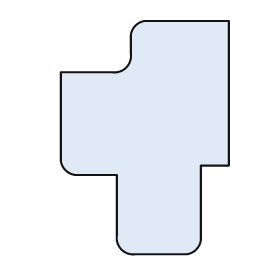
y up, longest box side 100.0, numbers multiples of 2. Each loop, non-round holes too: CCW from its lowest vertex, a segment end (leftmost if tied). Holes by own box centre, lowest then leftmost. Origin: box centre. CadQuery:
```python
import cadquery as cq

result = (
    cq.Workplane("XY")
    .moveTo(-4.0, -50.0)
    .lineTo(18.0, -50.0)
    .threePointArc((22.0, -48.0), (24.0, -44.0))
    .lineTo(24.0, -12.0)
    .lineTo(36.0, -12.0)
    .lineTo(36.0, 50.0)
    .lineTo(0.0, 50.0)
    .threePointArc((-4.0, 48.0), (-6.0, 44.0))
    .lineTo(-6.0, 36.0)
    .threePointArc((-8.0, 30.0), (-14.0, 28.0))
    .lineTo(-36.0, 28.0)
    .lineTo(-36.0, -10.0)
    .threePointArc((-34.0, -14.0), (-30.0, -16.0))
    .lineTo(-12.0, -16.0)
    .lineTo(-12.0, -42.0)
    .threePointArc((-10.0, -48.0), (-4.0, -50.0))
    .close()
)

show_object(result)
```